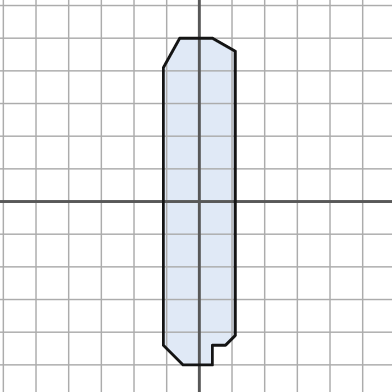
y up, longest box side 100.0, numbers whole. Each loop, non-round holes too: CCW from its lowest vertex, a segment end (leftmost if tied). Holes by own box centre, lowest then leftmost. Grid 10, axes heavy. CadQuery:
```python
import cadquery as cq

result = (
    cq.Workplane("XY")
    .moveTo(-5.0, -50.0)
    .lineTo(4.0, -50.0)
    .lineTo(4.0, -44.0)
    .lineTo(8.0, -44.0)
    .lineTo(11.0, -41.0)
    .lineTo(11.0, 46.0)
    .lineTo(4.0, 50.0)
    .lineTo(-6.0, 50.0)
    .lineTo(-11.0, 41.0)
    .lineTo(-11.0, -44.0)
    .close()
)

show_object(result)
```